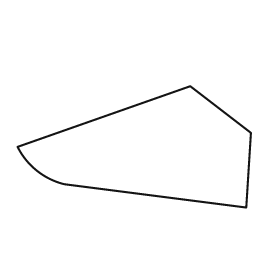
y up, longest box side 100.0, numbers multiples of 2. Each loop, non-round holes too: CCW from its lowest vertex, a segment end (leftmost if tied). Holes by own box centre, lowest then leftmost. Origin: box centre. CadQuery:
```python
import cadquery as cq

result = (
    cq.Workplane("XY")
    .moveTo(48.0, -26.0)
    .lineTo(50.0, 6.0)
    .lineTo(24.0, 26.0)
    .lineTo(-50.0, 0.0)
    .threePointArc((-42.0, -10.0), (-30.0, -16.0))
    .close()
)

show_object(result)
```